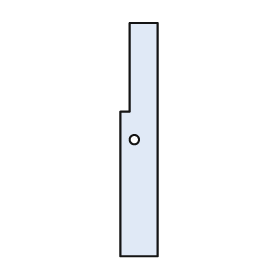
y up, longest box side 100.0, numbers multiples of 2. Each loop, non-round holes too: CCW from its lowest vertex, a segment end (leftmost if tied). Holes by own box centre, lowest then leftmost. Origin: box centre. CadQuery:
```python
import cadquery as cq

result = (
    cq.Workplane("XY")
    .moveTo(-8.0, -50.0)
    .lineTo(8.0, -50.0)
    .lineTo(8.0, 50.0)
    .lineTo(-4.0, 50.0)
    .lineTo(-4.0, 12.0)
    .lineTo(-8.0, 12.0)
    .close()
    .moveTo(-2.0, 0.0)
    .circle(2.0)
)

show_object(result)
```